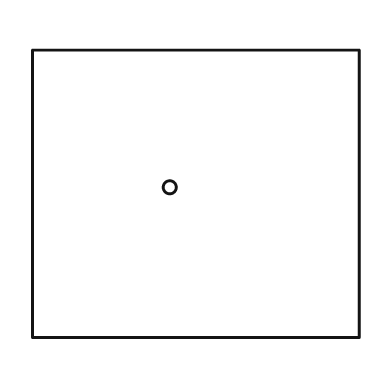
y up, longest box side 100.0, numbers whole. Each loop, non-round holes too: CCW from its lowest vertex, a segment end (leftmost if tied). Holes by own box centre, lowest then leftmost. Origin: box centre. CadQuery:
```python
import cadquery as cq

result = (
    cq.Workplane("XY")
    .moveTo(-50.0, -44.0)
    .lineTo(50.0, -44.0)
    .lineTo(50.0, 44.0)
    .lineTo(-50.0, 44.0)
    .close()
    .moveTo(-8.0, 2.0)
    .circle(2.0)
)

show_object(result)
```